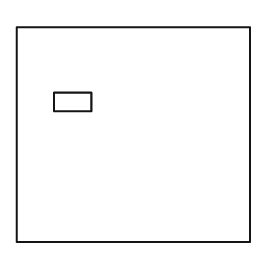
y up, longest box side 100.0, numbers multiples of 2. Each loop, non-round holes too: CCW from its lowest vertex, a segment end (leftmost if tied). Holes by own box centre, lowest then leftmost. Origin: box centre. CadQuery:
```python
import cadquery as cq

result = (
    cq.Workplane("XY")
    .moveTo(-50.0, -46.0)
    .lineTo(50.0, -46.0)
    .lineTo(50.0, 46.0)
    .lineTo(-50.0, 46.0)
    .close()
    .moveTo(-34.0, 10.0)
    .lineTo(-18.0, 10.0)
    .lineTo(-18.0, 18.0)
    .lineTo(-34.0, 18.0)
    .close()
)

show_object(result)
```